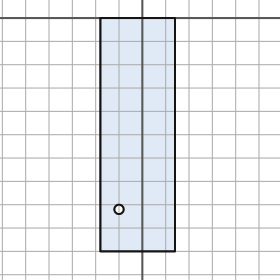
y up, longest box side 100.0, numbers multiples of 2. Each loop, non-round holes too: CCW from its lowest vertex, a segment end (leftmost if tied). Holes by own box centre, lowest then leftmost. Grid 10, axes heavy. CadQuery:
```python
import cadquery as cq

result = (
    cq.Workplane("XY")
    .moveTo(-18.0, -100.0)
    .lineTo(14.0, -100.0)
    .lineTo(14.0, 0.0)
    .lineTo(-18.0, 0.0)
    .close()
    .moveTo(-10.0, -82.0)
    .circle(2.0)
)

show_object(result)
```